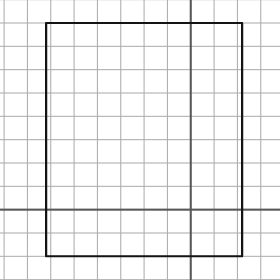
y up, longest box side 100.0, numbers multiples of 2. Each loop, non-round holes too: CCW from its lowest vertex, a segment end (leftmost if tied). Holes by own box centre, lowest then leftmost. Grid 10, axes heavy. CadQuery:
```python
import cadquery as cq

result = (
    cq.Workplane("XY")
    .moveTo(-62.0, -20.0)
    .lineTo(22.0, -20.0)
    .lineTo(22.0, 80.0)
    .lineTo(-62.0, 80.0)
    .close()
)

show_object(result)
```